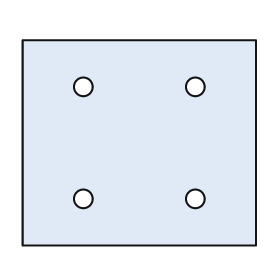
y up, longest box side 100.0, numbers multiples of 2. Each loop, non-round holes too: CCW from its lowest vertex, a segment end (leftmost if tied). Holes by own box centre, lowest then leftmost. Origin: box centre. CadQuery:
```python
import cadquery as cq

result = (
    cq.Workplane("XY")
    .moveTo(-50.0, -44.0)
    .lineTo(50.0, -44.0)
    .lineTo(50.0, 44.0)
    .lineTo(-50.0, 44.0)
    .close()
    .moveTo(-24.0, -24.0)
    .circle(4.0)
    .moveTo(24.0, -24.0)
    .circle(4.0)
    .moveTo(-24.0, 24.0)
    .circle(4.0)
    .moveTo(24.0, 24.0)
    .circle(4.0)
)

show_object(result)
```